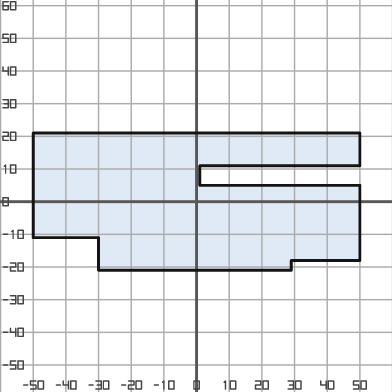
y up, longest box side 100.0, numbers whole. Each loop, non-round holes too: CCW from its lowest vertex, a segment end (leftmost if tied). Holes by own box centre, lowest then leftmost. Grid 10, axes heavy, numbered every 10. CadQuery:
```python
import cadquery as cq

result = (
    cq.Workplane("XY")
    .moveTo(-30.0, -21.0)
    .lineTo(29.0, -21.0)
    .lineTo(29.0, -18.0)
    .lineTo(50.0, -18.0)
    .lineTo(50.0, 5.0)
    .lineTo(1.0, 5.0)
    .lineTo(1.0, 11.0)
    .lineTo(50.0, 11.0)
    .lineTo(50.0, 21.0)
    .lineTo(-50.0, 21.0)
    .lineTo(-50.0, -11.0)
    .lineTo(-30.0, -11.0)
    .close()
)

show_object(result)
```